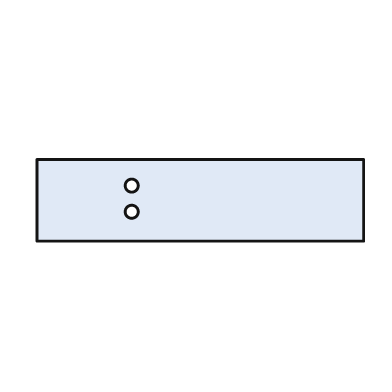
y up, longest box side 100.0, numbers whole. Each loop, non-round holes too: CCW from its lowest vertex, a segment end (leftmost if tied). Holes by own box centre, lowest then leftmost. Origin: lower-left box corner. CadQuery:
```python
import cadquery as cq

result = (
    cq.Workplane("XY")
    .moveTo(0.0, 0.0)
    .lineTo(100.0, 0.0)
    .lineTo(100.0, 25.0)
    .lineTo(0.0, 25.0)
    .close()
    .moveTo(29.0, 9.0)
    .circle(2.0)
    .moveTo(29.0, 17.0)
    .circle(2.0)
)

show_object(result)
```